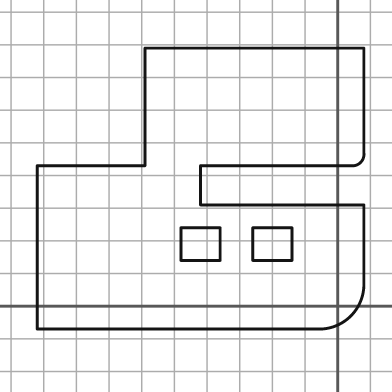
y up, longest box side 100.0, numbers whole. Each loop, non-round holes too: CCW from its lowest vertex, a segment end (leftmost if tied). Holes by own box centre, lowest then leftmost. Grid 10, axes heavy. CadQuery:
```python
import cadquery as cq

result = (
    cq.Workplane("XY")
    .moveTo(-92.0, -7.0)
    .lineTo(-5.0, -7.0)
    .threePointArc((4.0, -3.0), (8.0, 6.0))
    .lineTo(8.0, 31.0)
    .lineTo(-42.0, 31.0)
    .lineTo(-42.0, 43.0)
    .lineTo(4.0, 43.0)
    .threePointArc((7.0, 44.0), (8.0, 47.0))
    .lineTo(8.0, 79.0)
    .lineTo(-59.0, 79.0)
    .lineTo(-59.0, 43.0)
    .lineTo(-92.0, 43.0)
    .close()
    .moveTo(-48.0, 14.0)
    .lineTo(-36.0, 14.0)
    .lineTo(-36.0, 24.0)
    .lineTo(-48.0, 24.0)
    .close()
    .moveTo(-26.0, 14.0)
    .lineTo(-14.0, 14.0)
    .lineTo(-14.0, 24.0)
    .lineTo(-26.0, 24.0)
    .close()
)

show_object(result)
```